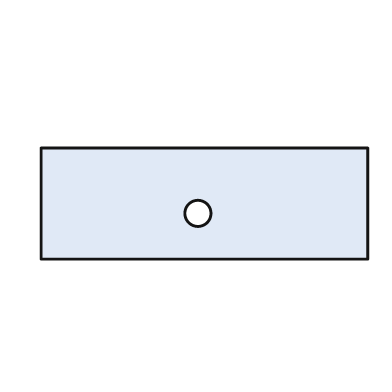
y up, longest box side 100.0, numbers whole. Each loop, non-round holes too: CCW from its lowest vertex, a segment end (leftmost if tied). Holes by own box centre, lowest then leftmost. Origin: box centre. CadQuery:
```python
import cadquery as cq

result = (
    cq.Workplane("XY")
    .moveTo(-50.0, -17.0)
    .lineTo(50.0, -17.0)
    .lineTo(50.0, 17.0)
    .lineTo(-50.0, 17.0)
    .close()
    .moveTo(-2.0, -3.0)
    .circle(4.0)
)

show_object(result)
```